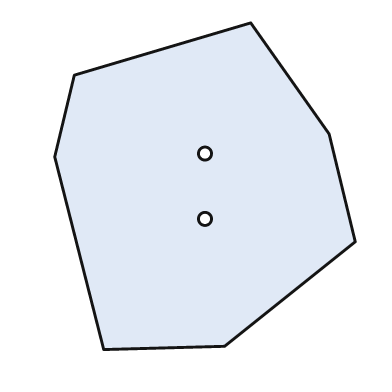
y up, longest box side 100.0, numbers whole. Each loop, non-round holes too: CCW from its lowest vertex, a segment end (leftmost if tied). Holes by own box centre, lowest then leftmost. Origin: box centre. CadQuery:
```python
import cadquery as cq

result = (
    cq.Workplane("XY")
    .moveTo(-31.0, -50.0)
    .lineTo(6.0, -49.0)
    .lineTo(46.0, -17.0)
    .lineTo(38.0, 16.0)
    .lineTo(14.0, 50.0)
    .lineTo(-40.0, 34.0)
    .lineTo(-46.0, 9.0)
    .close()
    .moveTo(0.0, -10.0)
    .circle(2.0)
    .moveTo(0.0, 10.0)
    .circle(2.0)
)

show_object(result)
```